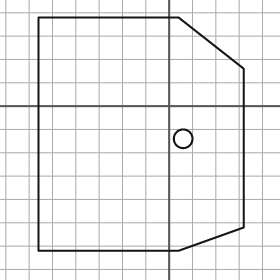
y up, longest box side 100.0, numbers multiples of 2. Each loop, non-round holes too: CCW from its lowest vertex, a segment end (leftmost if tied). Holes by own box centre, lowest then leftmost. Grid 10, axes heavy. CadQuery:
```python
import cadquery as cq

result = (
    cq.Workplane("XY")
    .moveTo(-56.0, -62.0)
    .lineTo(4.0, -62.0)
    .lineTo(32.0, -52.0)
    .lineTo(32.0, 16.0)
    .lineTo(4.0, 38.0)
    .lineTo(-56.0, 38.0)
    .close()
    .moveTo(6.0, -14.0)
    .circle(4.0)
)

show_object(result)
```